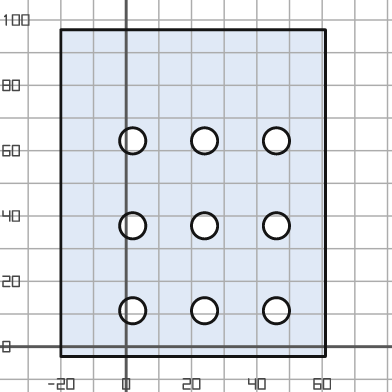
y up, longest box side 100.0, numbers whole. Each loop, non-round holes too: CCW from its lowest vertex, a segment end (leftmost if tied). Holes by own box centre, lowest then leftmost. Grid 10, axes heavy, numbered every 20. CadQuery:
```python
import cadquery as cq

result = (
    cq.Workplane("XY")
    .moveTo(-20.0, -3.0)
    .lineTo(61.0, -3.0)
    .lineTo(61.0, 97.0)
    .lineTo(-20.0, 97.0)
    .close()
    .moveTo(2.0, 11.0)
    .circle(4.0)
    .moveTo(24.0, 11.0)
    .circle(4.0)
    .moveTo(46.0, 11.0)
    .circle(4.0)
    .moveTo(2.0, 37.0)
    .circle(4.0)
    .moveTo(24.0, 37.0)
    .circle(4.0)
    .moveTo(46.0, 37.0)
    .circle(4.0)
    .moveTo(2.0, 63.0)
    .circle(4.0)
    .moveTo(24.0, 63.0)
    .circle(4.0)
    .moveTo(46.0, 63.0)
    .circle(4.0)
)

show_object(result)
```